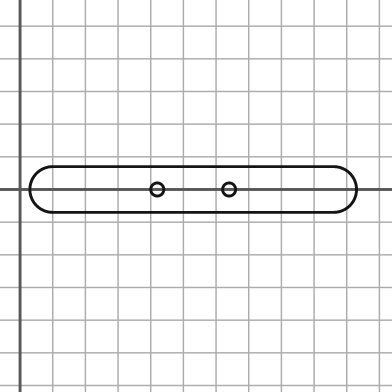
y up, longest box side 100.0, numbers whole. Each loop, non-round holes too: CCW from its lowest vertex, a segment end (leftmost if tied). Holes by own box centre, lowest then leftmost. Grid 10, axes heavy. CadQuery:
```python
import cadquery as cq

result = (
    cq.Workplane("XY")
    .moveTo(10.0, -7.0)
    .lineTo(96.0, -7.0)
    .threePointArc((103.0, 0.0), (96.0, 7.0))
    .lineTo(10.0, 7.0)
    .threePointArc((3.0, 0.0), (10.0, -7.0))
    .close()
    .moveTo(42.0, 0.0)
    .circle(2.0)
    .moveTo(64.0, 0.0)
    .circle(2.0)
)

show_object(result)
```